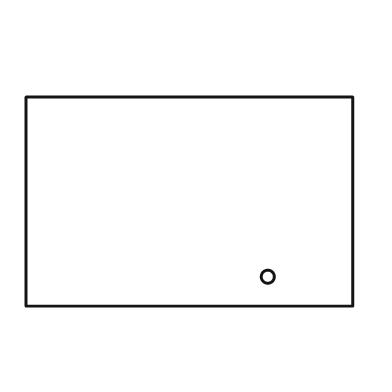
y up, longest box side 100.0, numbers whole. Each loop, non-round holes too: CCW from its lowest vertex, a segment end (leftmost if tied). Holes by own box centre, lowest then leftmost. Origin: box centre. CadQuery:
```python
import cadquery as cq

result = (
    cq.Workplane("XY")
    .moveTo(-50.0, -32.0)
    .lineTo(50.0, -32.0)
    .lineTo(50.0, 32.0)
    .lineTo(-50.0, 32.0)
    .close()
    .moveTo(24.0, -23.0)
    .circle(2.0)
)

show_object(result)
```